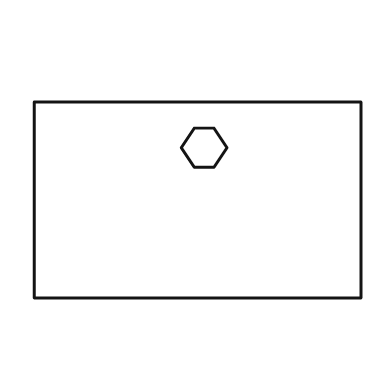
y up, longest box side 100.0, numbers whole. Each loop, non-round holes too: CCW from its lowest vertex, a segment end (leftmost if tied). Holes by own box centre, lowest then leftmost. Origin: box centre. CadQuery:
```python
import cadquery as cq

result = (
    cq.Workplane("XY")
    .moveTo(-50.0, -30.0)
    .lineTo(50.0, -30.0)
    .lineTo(50.0, 30.0)
    .lineTo(-50.0, 30.0)
    .close()
    .moveTo(-1.0, 10.0)
    .lineTo(5.0, 10.0)
    .lineTo(9.0, 16.0)
    .lineTo(5.0, 22.0)
    .lineTo(-1.0, 22.0)
    .lineTo(-5.0, 16.0)
    .close()
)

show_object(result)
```